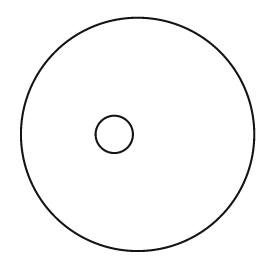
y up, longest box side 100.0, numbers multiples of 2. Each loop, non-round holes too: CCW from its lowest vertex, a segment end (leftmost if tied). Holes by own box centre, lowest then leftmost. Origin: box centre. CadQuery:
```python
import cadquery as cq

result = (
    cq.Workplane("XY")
    .moveTo(0.0, 0.0)
    .circle(50.0)
    .moveTo(-10.0, 0.0)
    .circle(8.0)
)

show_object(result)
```